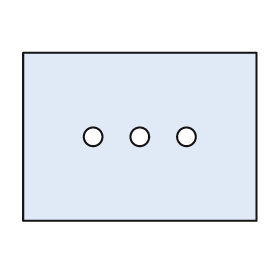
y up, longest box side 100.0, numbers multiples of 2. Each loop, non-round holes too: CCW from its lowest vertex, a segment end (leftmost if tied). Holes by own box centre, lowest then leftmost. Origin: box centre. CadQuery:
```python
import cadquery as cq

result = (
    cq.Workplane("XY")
    .moveTo(-50.0, -36.0)
    .lineTo(50.0, -36.0)
    .lineTo(50.0, 36.0)
    .lineTo(-50.0, 36.0)
    .close()
    .moveTo(-20.0, 0.0)
    .circle(4.0)
    .moveTo(0.0, 0.0)
    .circle(4.0)
    .moveTo(20.0, 0.0)
    .circle(4.0)
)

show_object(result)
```